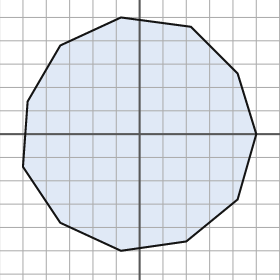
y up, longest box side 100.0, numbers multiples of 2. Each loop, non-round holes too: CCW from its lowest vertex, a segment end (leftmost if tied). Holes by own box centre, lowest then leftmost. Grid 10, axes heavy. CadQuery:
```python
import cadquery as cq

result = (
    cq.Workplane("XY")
    .moveTo(-8.0, -50.0)
    .lineTo(20.0, -46.0)
    .lineTo(42.0, -28.0)
    .lineTo(50.0, 0.0)
    .lineTo(42.0, 26.0)
    .lineTo(22.0, 46.0)
    .lineTo(-8.0, 50.0)
    .lineTo(-34.0, 38.0)
    .lineTo(-48.0, 14.0)
    .lineTo(-50.0, -14.0)
    .lineTo(-34.0, -38.0)
    .close()
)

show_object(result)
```